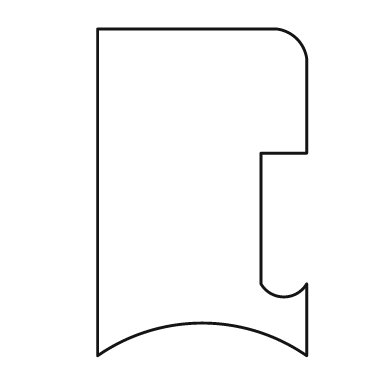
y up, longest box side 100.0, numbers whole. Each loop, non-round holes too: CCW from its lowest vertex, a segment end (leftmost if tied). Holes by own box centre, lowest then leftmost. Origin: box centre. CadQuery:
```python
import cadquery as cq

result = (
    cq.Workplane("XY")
    .moveTo(-32.0, -50.0)
    .threePointArc((0.0, -40.0), (32.0, -50.0))
    .lineTo(32.0, -28.0)
    .threePointArc((25.0, -32.0), (18.0, -28.0))
    .lineTo(18.0, 12.0)
    .lineTo(32.0, 12.0)
    .lineTo(32.0, 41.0)
    .threePointArc((29.0, 47.0), (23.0, 50.0))
    .lineTo(-32.0, 50.0)
    .close()
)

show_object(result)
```